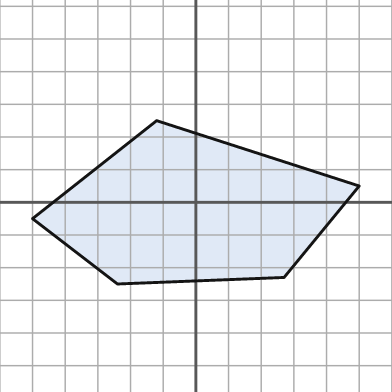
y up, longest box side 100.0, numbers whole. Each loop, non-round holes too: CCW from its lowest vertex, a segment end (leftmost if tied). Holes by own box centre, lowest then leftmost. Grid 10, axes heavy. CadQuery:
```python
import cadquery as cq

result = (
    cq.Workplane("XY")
    .moveTo(-24.0, -25.0)
    .lineTo(27.0, -23.0)
    .lineTo(50.0, 5.0)
    .lineTo(-12.0, 25.0)
    .lineTo(-50.0, -5.0)
    .close()
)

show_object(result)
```